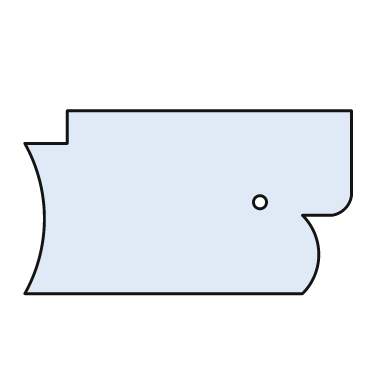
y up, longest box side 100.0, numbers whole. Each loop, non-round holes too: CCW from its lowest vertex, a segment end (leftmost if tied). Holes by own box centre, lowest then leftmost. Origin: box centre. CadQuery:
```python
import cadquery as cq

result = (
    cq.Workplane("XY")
    .moveTo(-50.0, -28.0)
    .lineTo(35.0, -28.0)
    .threePointArc((40.0, -16.0), (35.0, -4.0))
    .lineTo(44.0, -4.0)
    .threePointArc((48.0, -2.0), (50.0, 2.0))
    .lineTo(50.0, 28.0)
    .lineTo(-37.0, 28.0)
    .lineTo(-37.0, 18.0)
    .lineTo(-50.0, 18.0)
    .threePointArc((-44.0, -5.0), (-50.0, -28.0))
    .close()
    .moveTo(22.0, 0.0)
    .circle(2.0)
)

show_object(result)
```